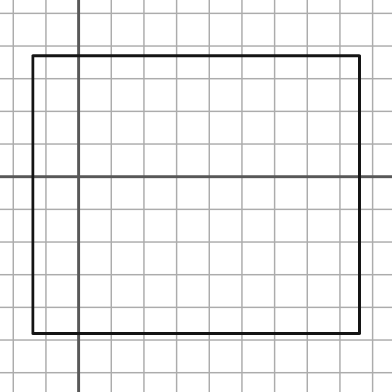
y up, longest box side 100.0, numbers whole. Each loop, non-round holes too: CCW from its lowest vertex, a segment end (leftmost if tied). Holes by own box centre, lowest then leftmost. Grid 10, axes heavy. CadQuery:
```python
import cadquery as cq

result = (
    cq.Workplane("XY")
    .moveTo(-14.0, -48.0)
    .lineTo(86.0, -48.0)
    .lineTo(86.0, 37.0)
    .lineTo(-14.0, 37.0)
    .close()
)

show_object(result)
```